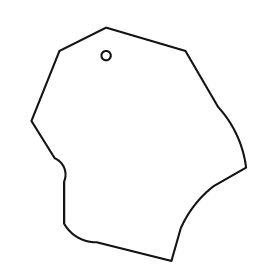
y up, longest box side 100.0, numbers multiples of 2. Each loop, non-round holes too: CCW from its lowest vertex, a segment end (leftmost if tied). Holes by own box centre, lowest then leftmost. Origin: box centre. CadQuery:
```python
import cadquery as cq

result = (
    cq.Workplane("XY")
    .moveTo(14.0, -50.0)
    .lineTo(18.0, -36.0)
    .threePointArc((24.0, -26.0), (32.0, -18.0))
    .lineTo(46.0, -10.0)
    .threePointArc((42.0, 4.0), (34.0, 16.0))
    .lineTo(20.0, 40.0)
    .lineTo(-14.0, 50.0)
    .lineTo(-34.0, 40.0)
    .lineTo(-46.0, 10.0)
    .lineTo(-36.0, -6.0)
    .threePointArc((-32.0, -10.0), (-32.0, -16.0))
    .lineTo(-32.0, -34.0)
    .threePointArc((-26.0, -40.0), (-18.0, -42.0))
    .close()
    .moveTo(-14.0, 38.0)
    .circle(2.0)
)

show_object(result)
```